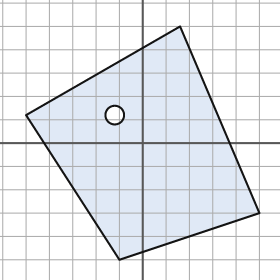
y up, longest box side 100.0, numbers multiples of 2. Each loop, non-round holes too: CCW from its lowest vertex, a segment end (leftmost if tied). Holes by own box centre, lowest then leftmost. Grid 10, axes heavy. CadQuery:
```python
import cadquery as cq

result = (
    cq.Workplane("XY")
    .moveTo(-10.0, -50.0)
    .lineTo(50.0, -30.0)
    .lineTo(16.0, 50.0)
    .lineTo(-50.0, 12.0)
    .close()
    .moveTo(-12.0, 12.0)
    .circle(4.0)
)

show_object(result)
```